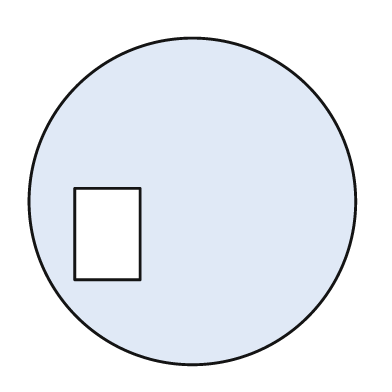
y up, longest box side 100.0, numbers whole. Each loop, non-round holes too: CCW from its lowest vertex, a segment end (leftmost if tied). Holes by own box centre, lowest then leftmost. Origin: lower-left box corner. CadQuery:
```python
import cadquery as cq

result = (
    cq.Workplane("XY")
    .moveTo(50.0, 50.0)
    .circle(50.0)
    .moveTo(14.0, 26.0)
    .lineTo(34.0, 26.0)
    .lineTo(34.0, 54.0)
    .lineTo(14.0, 54.0)
    .close()
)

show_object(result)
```